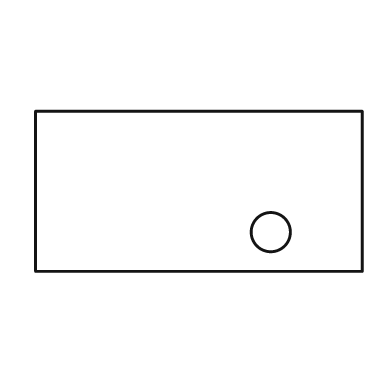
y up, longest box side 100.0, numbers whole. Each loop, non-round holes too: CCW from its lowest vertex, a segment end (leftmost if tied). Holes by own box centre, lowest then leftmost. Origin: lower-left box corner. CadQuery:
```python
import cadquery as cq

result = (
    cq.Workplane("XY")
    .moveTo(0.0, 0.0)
    .lineTo(100.0, 0.0)
    .lineTo(100.0, 49.0)
    .lineTo(0.0, 49.0)
    .close()
    .moveTo(72.0, 12.0)
    .circle(6.0)
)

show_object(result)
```